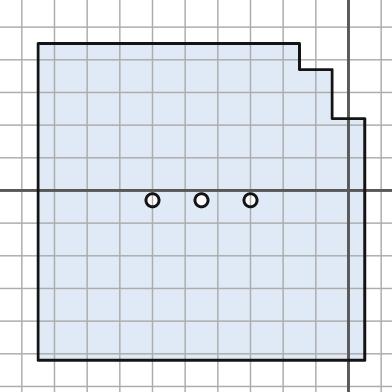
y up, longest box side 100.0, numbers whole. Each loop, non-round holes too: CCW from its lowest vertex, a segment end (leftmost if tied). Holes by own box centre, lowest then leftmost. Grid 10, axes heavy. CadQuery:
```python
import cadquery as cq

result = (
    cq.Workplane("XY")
    .moveTo(-95.0, -52.0)
    .lineTo(5.0, -52.0)
    .lineTo(5.0, 22.0)
    .lineTo(-5.0, 22.0)
    .lineTo(-5.0, 37.0)
    .lineTo(-15.0, 37.0)
    .lineTo(-15.0, 45.0)
    .lineTo(-95.0, 45.0)
    .close()
    .moveTo(-60.0, -3.0)
    .circle(2.0)
    .moveTo(-45.0, -3.0)
    .circle(2.0)
    .moveTo(-30.0, -3.0)
    .circle(2.0)
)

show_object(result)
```